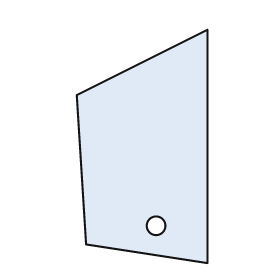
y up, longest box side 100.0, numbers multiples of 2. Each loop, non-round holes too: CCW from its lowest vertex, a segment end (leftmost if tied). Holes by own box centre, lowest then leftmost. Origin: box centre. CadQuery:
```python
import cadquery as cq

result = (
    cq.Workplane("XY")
    .moveTo(28.0, -50.0)
    .lineTo(28.0, 50.0)
    .lineTo(-28.0, 22.0)
    .lineTo(-24.0, -42.0)
    .close()
    .moveTo(6.0, -34.0)
    .circle(4.0)
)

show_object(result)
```